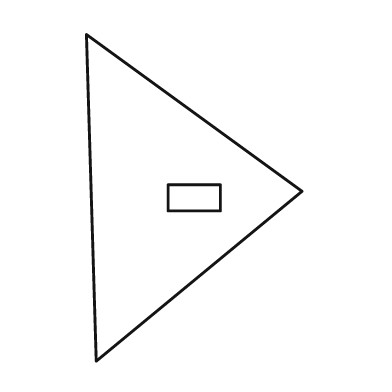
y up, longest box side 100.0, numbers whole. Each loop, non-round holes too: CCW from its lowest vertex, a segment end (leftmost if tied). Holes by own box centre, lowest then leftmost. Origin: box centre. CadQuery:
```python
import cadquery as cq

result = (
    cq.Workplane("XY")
    .moveTo(-30.0, -50.0)
    .lineTo(33.0, 2.0)
    .lineTo(-33.0, 50.0)
    .close()
    .moveTo(-8.0, -4.0)
    .lineTo(8.0, -4.0)
    .lineTo(8.0, 4.0)
    .lineTo(-8.0, 4.0)
    .close()
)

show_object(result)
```